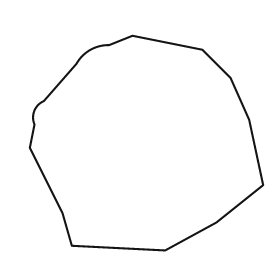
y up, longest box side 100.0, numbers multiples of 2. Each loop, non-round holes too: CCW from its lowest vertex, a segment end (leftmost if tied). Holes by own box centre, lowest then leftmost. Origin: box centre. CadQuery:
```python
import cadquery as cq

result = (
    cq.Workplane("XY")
    .moveTo(8.0, -46.0)
    .lineTo(30.0, -34.0)
    .lineTo(50.0, -18.0)
    .lineTo(44.0, 10.0)
    .lineTo(36.0, 28.0)
    .lineTo(24.0, 40.0)
    .lineTo(-6.0, 46.0)
    .lineTo(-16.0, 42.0)
    .threePointArc((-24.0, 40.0), (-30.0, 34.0))
    .lineTo(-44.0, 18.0)
    .threePointArc((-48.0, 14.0), (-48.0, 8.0))
    .lineTo(-50.0, -2.0)
    .lineTo(-36.0, -30.0)
    .lineTo(-32.0, -44.0)
    .close()
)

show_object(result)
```